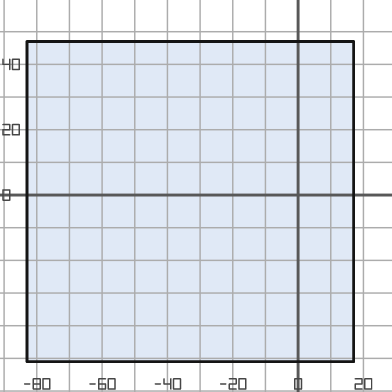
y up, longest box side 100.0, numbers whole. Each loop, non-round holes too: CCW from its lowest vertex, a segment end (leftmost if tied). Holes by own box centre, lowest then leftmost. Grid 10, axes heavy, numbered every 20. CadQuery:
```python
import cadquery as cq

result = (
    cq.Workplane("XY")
    .moveTo(-83.0, -51.0)
    .lineTo(17.0, -51.0)
    .lineTo(17.0, 47.0)
    .lineTo(-83.0, 47.0)
    .close()
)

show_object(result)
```